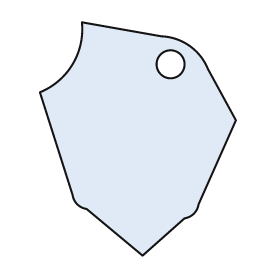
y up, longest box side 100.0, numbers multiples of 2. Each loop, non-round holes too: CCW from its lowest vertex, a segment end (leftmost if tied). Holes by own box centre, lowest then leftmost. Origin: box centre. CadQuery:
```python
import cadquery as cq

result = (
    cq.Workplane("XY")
    .moveTo(2.0, -50.0)
    .lineTo(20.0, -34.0)
    .threePointArc((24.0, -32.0), (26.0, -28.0))
    .lineTo(42.0, 8.0)
    .lineTo(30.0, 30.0)
    .threePointArc((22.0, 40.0), (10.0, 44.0))
    .lineTo(-24.0, 50.0)
    .threePointArc((-28.0, 32.0), (-42.0, 20.0))
    .lineTo(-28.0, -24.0)
    .threePointArc((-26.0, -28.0), (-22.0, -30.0))
    .close()
    .moveTo(14.0, 32.0)
    .circle(6.0)
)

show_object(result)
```